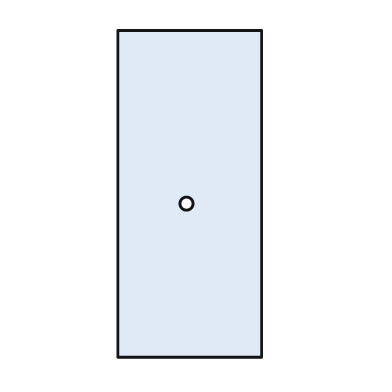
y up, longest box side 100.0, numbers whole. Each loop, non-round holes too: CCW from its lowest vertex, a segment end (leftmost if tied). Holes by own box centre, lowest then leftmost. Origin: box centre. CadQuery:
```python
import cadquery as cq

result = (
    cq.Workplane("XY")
    .moveTo(-22.0, -50.0)
    .lineTo(22.0, -50.0)
    .lineTo(22.0, 50.0)
    .lineTo(-22.0, 50.0)
    .close()
    .moveTo(-1.0, -3.0)
    .circle(2.0)
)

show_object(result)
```